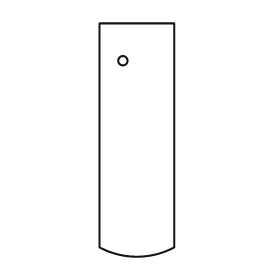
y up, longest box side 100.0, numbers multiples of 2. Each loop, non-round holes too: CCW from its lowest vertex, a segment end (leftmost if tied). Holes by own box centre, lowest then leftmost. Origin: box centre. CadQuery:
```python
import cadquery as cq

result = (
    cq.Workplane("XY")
    .moveTo(-16.0, -46.0)
    .threePointArc((0.0, -50.0), (16.0, -46.0))
    .lineTo(16.0, 50.0)
    .lineTo(-16.0, 50.0)
    .close()
    .moveTo(-6.0, 34.0)
    .circle(2.0)
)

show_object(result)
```